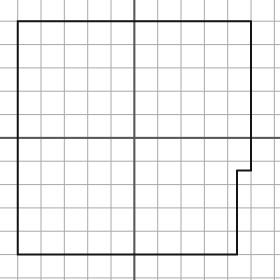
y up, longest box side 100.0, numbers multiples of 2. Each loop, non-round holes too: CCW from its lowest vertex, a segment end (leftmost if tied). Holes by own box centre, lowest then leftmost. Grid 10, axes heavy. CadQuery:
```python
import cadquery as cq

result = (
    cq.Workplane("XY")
    .moveTo(-50.0, -50.0)
    .lineTo(44.0, -50.0)
    .lineTo(44.0, -14.0)
    .lineTo(50.0, -14.0)
    .lineTo(50.0, 50.0)
    .lineTo(-50.0, 50.0)
    .close()
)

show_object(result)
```